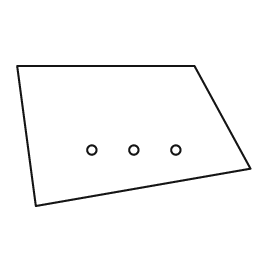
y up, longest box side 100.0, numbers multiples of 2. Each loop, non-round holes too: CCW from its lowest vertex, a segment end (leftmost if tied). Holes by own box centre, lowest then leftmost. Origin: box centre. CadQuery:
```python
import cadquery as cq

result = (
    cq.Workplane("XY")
    .moveTo(-42.0, -30.0)
    .lineTo(50.0, -14.0)
    .lineTo(26.0, 30.0)
    .lineTo(-50.0, 30.0)
    .close()
    .moveTo(-18.0, -6.0)
    .circle(2.0)
    .moveTo(0.0, -6.0)
    .circle(2.0)
    .moveTo(18.0, -6.0)
    .circle(2.0)
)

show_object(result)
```